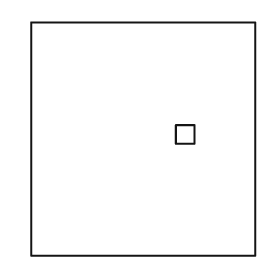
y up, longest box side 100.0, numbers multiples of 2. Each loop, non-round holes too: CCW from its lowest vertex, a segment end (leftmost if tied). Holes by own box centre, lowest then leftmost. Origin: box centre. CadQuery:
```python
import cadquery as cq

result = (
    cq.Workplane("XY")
    .moveTo(-48.0, -50.0)
    .lineTo(48.0, -50.0)
    .lineTo(48.0, 50.0)
    .lineTo(-48.0, 50.0)
    .close()
    .moveTo(14.0, -2.0)
    .lineTo(22.0, -2.0)
    .lineTo(22.0, 6.0)
    .lineTo(14.0, 6.0)
    .close()
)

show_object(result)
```